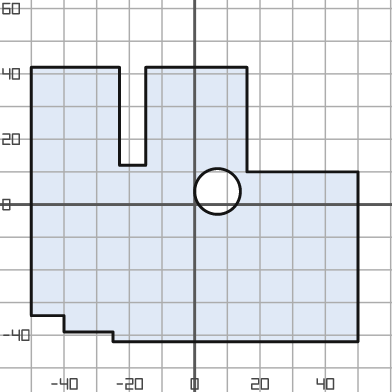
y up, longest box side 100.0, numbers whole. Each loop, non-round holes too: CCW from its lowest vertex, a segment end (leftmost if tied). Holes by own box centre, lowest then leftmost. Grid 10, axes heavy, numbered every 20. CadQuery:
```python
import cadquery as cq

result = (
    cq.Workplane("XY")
    .moveTo(-25.0, -42.0)
    .lineTo(50.0, -42.0)
    .lineTo(50.0, 10.0)
    .lineTo(16.0, 10.0)
    .lineTo(16.0, 42.0)
    .lineTo(-15.0, 42.0)
    .lineTo(-15.0, 12.0)
    .lineTo(-23.0, 12.0)
    .lineTo(-23.0, 42.0)
    .lineTo(-50.0, 42.0)
    .lineTo(-50.0, -34.0)
    .lineTo(-40.0, -34.0)
    .lineTo(-40.0, -39.0)
    .lineTo(-25.0, -39.0)
    .close()
    .moveTo(7.0, 4.0)
    .circle(7.0)
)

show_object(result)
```